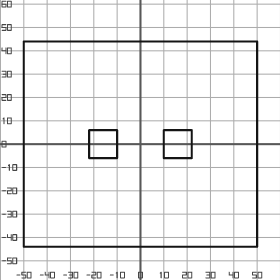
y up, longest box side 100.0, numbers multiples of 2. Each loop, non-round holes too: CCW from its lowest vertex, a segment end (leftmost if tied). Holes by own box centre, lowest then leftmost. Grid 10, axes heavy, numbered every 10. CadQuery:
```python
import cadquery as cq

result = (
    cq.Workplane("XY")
    .moveTo(-50.0, -44.0)
    .lineTo(50.0, -44.0)
    .lineTo(50.0, 44.0)
    .lineTo(-50.0, 44.0)
    .close()
    .moveTo(-22.0, -6.0)
    .lineTo(-10.0, -6.0)
    .lineTo(-10.0, 6.0)
    .lineTo(-22.0, 6.0)
    .close()
    .moveTo(10.0, -6.0)
    .lineTo(22.0, -6.0)
    .lineTo(22.0, 6.0)
    .lineTo(10.0, 6.0)
    .close()
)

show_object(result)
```